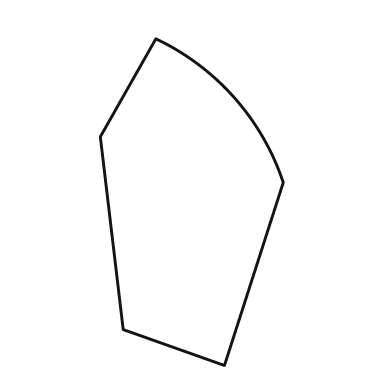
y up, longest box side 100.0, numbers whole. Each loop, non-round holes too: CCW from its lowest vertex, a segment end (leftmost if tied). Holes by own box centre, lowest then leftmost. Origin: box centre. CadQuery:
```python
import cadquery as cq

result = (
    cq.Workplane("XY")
    .moveTo(10.0, -50.0)
    .lineTo(28.0, 6.0)
    .threePointArc((13.0, 32.0), (-11.0, 50.0))
    .lineTo(-28.0, 20.0)
    .lineTo(-21.0, -39.0)
    .close()
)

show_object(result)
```